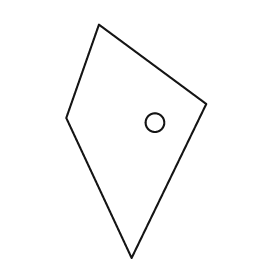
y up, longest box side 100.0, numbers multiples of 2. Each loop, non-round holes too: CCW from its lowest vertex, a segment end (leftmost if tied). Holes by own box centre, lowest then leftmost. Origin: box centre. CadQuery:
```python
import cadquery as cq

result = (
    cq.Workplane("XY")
    .moveTo(-2.0, -50.0)
    .lineTo(30.0, 16.0)
    .lineTo(-16.0, 50.0)
    .lineTo(-30.0, 10.0)
    .close()
    .moveTo(8.0, 8.0)
    .circle(4.0)
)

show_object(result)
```